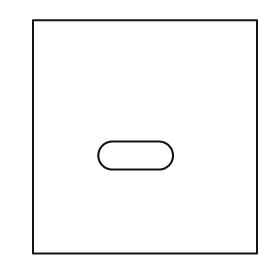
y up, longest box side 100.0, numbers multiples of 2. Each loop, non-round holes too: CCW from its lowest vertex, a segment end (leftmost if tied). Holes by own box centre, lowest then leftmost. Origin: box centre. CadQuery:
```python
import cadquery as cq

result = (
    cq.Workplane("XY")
    .moveTo(-48.0, -50.0)
    .lineTo(48.0, -50.0)
    .lineTo(48.0, 50.0)
    .lineTo(-48.0, 50.0)
    .close()
    .moveTo(-14.0, -14.0)
    .lineTo(6.0, -14.0)
    .threePointArc((12.0, -8.0), (6.0, -2.0))
    .lineTo(-14.0, -2.0)
    .threePointArc((-20.0, -8.0), (-14.0, -14.0))
    .close()
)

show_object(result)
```